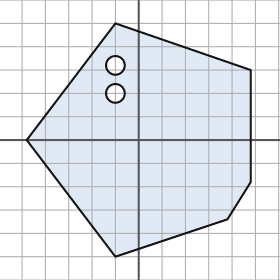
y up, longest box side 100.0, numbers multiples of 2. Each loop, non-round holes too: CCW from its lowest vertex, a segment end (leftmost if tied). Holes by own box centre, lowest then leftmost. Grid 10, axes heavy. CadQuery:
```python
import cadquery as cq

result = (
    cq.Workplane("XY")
    .moveTo(-10.0, -50.0)
    .lineTo(38.0, -34.0)
    .lineTo(48.0, -18.0)
    .lineTo(48.0, 30.0)
    .lineTo(-10.0, 50.0)
    .lineTo(-48.0, 0.0)
    .close()
    .moveTo(-10.0, 20.0)
    .circle(4.0)
    .moveTo(-10.0, 32.0)
    .circle(4.0)
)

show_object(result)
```